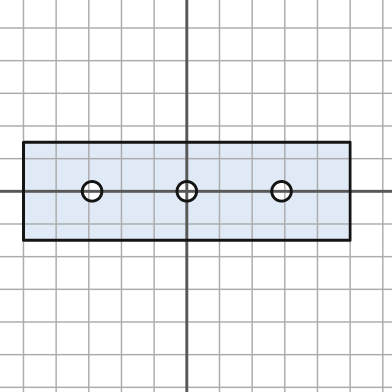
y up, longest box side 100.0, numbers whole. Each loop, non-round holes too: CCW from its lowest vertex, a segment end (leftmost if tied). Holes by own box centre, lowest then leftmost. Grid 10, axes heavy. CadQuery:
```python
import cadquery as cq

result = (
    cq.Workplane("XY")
    .moveTo(-50.0, -15.0)
    .lineTo(50.0, -15.0)
    .lineTo(50.0, 15.0)
    .lineTo(-50.0, 15.0)
    .close()
    .moveTo(-29.0, 0.0)
    .circle(3.0)
    .moveTo(0.0, 0.0)
    .circle(3.0)
    .moveTo(29.0, 0.0)
    .circle(3.0)
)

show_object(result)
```